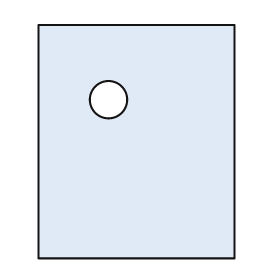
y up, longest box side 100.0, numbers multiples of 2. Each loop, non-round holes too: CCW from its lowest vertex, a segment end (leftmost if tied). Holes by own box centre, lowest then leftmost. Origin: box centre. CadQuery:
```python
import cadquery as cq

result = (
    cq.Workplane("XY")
    .moveTo(-42.0, -50.0)
    .lineTo(42.0, -50.0)
    .lineTo(42.0, 50.0)
    .lineTo(-42.0, 50.0)
    .close()
    .moveTo(-12.0, 18.0)
    .circle(8.0)
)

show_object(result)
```